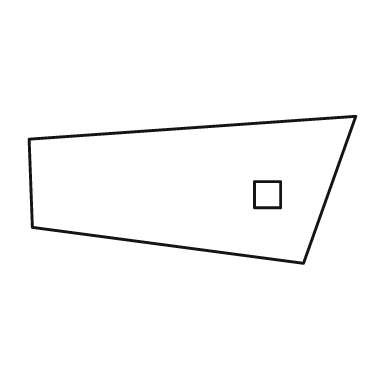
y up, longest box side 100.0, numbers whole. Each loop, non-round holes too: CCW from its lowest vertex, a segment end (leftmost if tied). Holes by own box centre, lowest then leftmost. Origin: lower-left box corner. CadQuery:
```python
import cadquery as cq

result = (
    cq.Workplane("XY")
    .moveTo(84.0, 0.0)
    .lineTo(100.0, 45.0)
    .lineTo(0.0, 38.0)
    .lineTo(1.0, 11.0)
    .close()
    .moveTo(69.0, 17.0)
    .lineTo(77.0, 17.0)
    .lineTo(77.0, 25.0)
    .lineTo(69.0, 25.0)
    .close()
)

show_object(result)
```